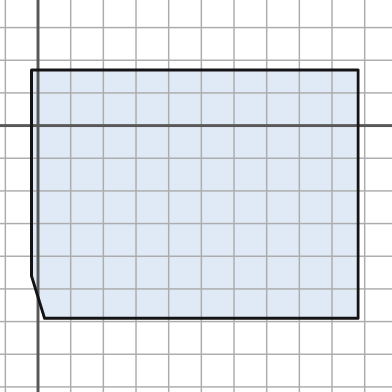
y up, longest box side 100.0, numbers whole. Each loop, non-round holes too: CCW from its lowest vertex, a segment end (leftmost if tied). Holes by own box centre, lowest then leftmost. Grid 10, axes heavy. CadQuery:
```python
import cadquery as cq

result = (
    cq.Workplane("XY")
    .moveTo(2.0, -59.0)
    .lineTo(98.0, -59.0)
    .lineTo(98.0, 17.0)
    .lineTo(-2.0, 17.0)
    .lineTo(-2.0, -46.0)
    .close()
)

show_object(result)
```